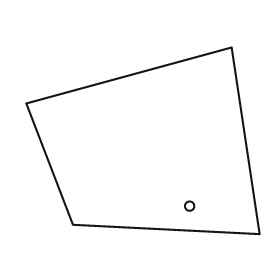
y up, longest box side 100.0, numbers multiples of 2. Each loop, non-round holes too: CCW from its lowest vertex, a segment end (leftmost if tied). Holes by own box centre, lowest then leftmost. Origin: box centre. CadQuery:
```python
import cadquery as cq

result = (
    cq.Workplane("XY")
    .moveTo(50.0, -40.0)
    .lineTo(38.0, 40.0)
    .lineTo(-50.0, 16.0)
    .lineTo(-30.0, -36.0)
    .close()
    .moveTo(20.0, -28.0)
    .circle(2.0)
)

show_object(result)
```